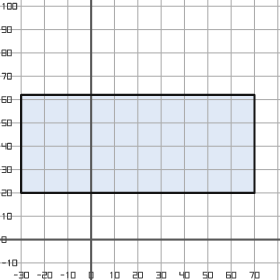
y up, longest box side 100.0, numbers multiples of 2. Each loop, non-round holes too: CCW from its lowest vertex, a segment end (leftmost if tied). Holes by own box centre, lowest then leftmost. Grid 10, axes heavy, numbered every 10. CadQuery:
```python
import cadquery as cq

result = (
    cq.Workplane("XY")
    .moveTo(-30.0, 20.0)
    .lineTo(70.0, 20.0)
    .lineTo(70.0, 62.0)
    .lineTo(-30.0, 62.0)
    .close()
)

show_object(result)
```